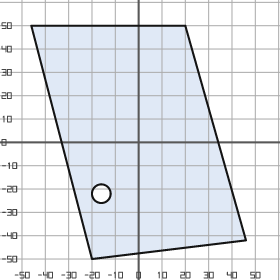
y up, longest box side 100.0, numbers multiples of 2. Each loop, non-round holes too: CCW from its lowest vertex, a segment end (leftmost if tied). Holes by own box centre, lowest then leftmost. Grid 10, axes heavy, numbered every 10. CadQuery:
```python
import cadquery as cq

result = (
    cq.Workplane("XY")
    .moveTo(-20.0, -50.0)
    .lineTo(46.0, -42.0)
    .lineTo(20.0, 50.0)
    .lineTo(-46.0, 50.0)
    .close()
    .moveTo(-16.0, -22.0)
    .circle(4.0)
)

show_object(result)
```